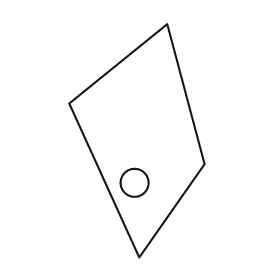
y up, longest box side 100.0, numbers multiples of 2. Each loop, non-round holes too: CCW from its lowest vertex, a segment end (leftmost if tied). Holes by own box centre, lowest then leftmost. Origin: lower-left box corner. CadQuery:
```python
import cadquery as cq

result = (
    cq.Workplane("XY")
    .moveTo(30.0, 0.0)
    .lineTo(58.0, 40.0)
    .lineTo(42.0, 100.0)
    .lineTo(0.0, 66.0)
    .close()
    .moveTo(28.0, 32.0)
    .circle(6.0)
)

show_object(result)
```